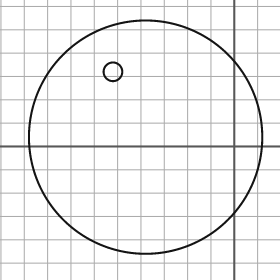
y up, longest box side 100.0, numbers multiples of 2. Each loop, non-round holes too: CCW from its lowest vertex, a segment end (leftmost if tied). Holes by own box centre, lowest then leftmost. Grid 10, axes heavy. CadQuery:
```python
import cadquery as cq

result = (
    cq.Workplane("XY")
    .moveTo(-38.0, 4.0)
    .circle(50.0)
    .moveTo(-52.0, 32.0)
    .circle(4.0)
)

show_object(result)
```